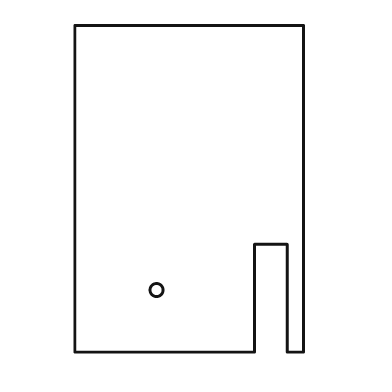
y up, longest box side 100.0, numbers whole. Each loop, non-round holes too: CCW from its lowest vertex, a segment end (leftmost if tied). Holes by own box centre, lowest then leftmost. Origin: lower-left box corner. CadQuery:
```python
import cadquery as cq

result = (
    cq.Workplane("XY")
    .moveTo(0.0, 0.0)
    .lineTo(55.0, 0.0)
    .lineTo(55.0, 33.0)
    .lineTo(65.0, 33.0)
    .lineTo(65.0, 0.0)
    .lineTo(70.0, 0.0)
    .lineTo(70.0, 100.0)
    .lineTo(0.0, 100.0)
    .close()
    .moveTo(25.0, 19.0)
    .circle(2.0)
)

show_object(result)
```